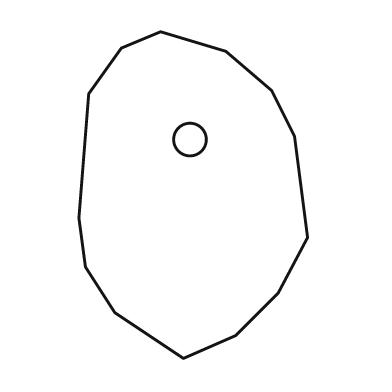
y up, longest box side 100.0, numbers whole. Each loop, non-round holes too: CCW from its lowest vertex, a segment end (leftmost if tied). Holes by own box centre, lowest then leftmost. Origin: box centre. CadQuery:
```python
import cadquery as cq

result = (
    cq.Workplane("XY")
    .moveTo(-3.0, -50.0)
    .lineTo(13.0, -43.0)
    .lineTo(26.0, -30.0)
    .lineTo(35.0, -13.0)
    .lineTo(31.0, 18.0)
    .lineTo(24.0, 32.0)
    .lineTo(10.0, 44.0)
    .lineTo(-10.0, 50.0)
    .lineTo(-22.0, 45.0)
    .lineTo(-32.0, 31.0)
    .lineTo(-35.0, -7.0)
    .lineTo(-33.0, -22.0)
    .lineTo(-24.0, -36.0)
    .close()
    .moveTo(-1.0, 17.0)
    .circle(5.0)
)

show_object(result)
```